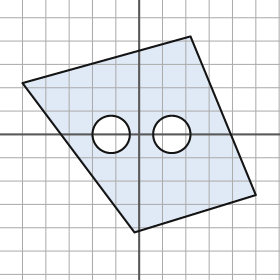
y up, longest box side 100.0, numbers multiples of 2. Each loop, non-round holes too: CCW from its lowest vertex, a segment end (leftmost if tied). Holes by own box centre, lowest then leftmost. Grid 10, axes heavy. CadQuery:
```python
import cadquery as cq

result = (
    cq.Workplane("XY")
    .moveTo(-2.0, -42.0)
    .lineTo(50.0, -26.0)
    .lineTo(22.0, 42.0)
    .lineTo(-50.0, 22.0)
    .close()
    .moveTo(-12.0, 0.0)
    .circle(8.0)
    .moveTo(14.0, 0.0)
    .circle(8.0)
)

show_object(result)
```